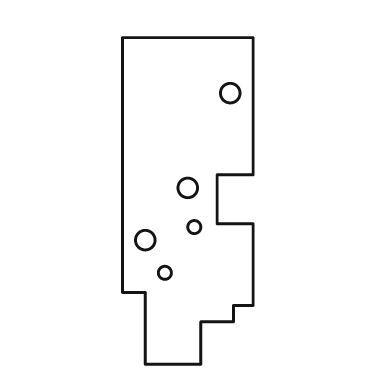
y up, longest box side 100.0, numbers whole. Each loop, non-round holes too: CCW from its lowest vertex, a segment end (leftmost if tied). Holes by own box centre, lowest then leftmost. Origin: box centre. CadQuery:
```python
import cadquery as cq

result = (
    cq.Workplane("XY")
    .moveTo(-13.0, -50.0)
    .lineTo(4.0, -50.0)
    .lineTo(4.0, -37.0)
    .lineTo(14.0, -37.0)
    .lineTo(14.0, -32.0)
    .lineTo(20.0, -32.0)
    .lineTo(20.0, -7.0)
    .lineTo(9.0, -7.0)
    .lineTo(9.0, 8.0)
    .lineTo(20.0, 8.0)
    .lineTo(20.0, 50.0)
    .lineTo(-20.0, 50.0)
    .lineTo(-20.0, -28.0)
    .lineTo(-13.0, -28.0)
    .close()
    .moveTo(-7.0, -22.0)
    .circle(2.0)
    .moveTo(-13.0, -12.0)
    .circle(3.0)
    .moveTo(2.0, -8.0)
    .circle(2.0)
    .moveTo(0.0, 4.0)
    .circle(3.0)
    .moveTo(13.0, 33.0)
    .circle(3.0)
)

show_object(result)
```